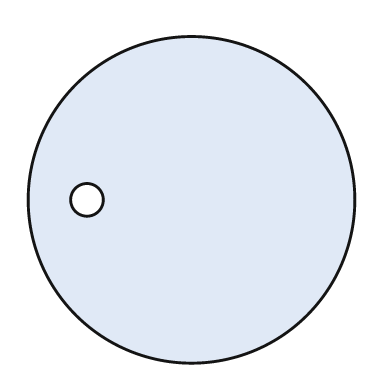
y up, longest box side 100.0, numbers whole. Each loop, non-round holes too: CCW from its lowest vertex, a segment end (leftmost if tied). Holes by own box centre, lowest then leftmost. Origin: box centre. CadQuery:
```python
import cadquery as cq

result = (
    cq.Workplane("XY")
    .moveTo(0.0, 0.0)
    .circle(50.0)
    .moveTo(-32.0, 0.0)
    .circle(5.0)
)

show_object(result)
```